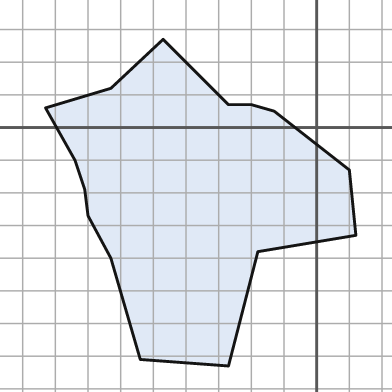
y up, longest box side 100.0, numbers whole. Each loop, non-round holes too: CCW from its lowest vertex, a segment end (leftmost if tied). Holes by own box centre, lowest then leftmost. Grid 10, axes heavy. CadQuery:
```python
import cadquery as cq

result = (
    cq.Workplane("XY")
    .moveTo(-27.0, -73.0)
    .lineTo(-18.0, -38.0)
    .lineTo(12.0, -33.0)
    .lineTo(10.0, -13.0)
    .lineTo(-13.0, 5.0)
    .lineTo(-20.0, 7.0)
    .lineTo(-27.0, 7.0)
    .lineTo(-47.0, 27.0)
    .lineTo(-63.0, 12.0)
    .lineTo(-83.0, 6.0)
    .lineTo(-74.0, -10.0)
    .lineTo(-71.0, -19.0)
    .lineTo(-70.0, -27.0)
    .lineTo(-63.0, -40.0)
    .lineTo(-54.0, -71.0)
    .close()
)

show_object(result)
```